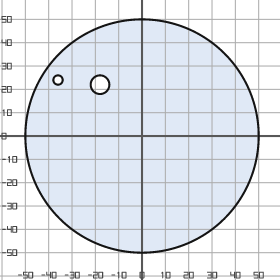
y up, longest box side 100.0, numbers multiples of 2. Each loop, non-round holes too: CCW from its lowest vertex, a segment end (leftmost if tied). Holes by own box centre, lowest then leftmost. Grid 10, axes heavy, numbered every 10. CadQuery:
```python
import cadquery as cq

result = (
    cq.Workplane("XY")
    .moveTo(0.0, 0.0)
    .circle(50.0)
    .moveTo(-18.0, 22.0)
    .circle(4.0)
    .moveTo(-36.0, 24.0)
    .circle(2.0)
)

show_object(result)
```